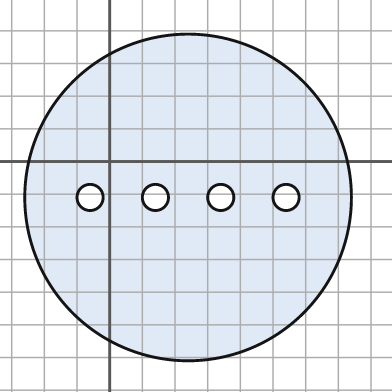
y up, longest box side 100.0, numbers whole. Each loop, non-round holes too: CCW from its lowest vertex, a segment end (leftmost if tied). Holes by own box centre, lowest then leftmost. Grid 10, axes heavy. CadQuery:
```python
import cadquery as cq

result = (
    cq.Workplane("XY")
    .moveTo(24.0, -11.0)
    .circle(50.0)
    .moveTo(-6.0, -11.0)
    .circle(4.0)
    .moveTo(14.0, -11.0)
    .circle(4.0)
    .moveTo(34.0, -11.0)
    .circle(4.0)
    .moveTo(54.0, -11.0)
    .circle(4.0)
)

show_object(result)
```